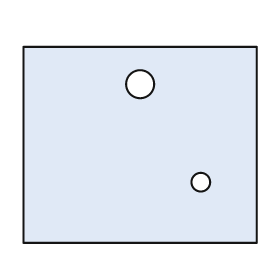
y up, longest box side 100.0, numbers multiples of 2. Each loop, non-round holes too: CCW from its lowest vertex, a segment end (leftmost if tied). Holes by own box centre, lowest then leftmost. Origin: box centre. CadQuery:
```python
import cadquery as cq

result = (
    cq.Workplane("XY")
    .moveTo(-50.0, -42.0)
    .lineTo(50.0, -42.0)
    .lineTo(50.0, 42.0)
    .lineTo(-50.0, 42.0)
    .close()
    .moveTo(26.0, -16.0)
    .circle(4.0)
    .moveTo(0.0, 26.0)
    .circle(6.0)
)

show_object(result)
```